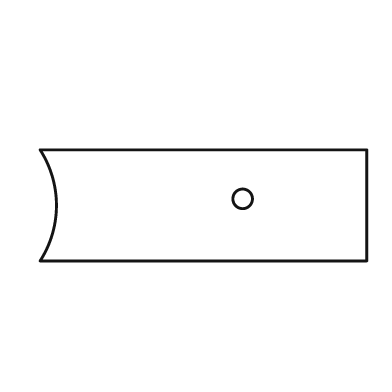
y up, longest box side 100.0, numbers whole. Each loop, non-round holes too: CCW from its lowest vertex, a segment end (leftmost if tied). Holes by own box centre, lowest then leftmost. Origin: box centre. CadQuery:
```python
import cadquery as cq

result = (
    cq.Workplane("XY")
    .moveTo(-50.0, -17.0)
    .lineTo(50.0, -17.0)
    .lineTo(50.0, 17.0)
    .lineTo(-50.0, 17.0)
    .threePointArc((-45.0, 0.0), (-50.0, -17.0))
    .close()
    .moveTo(12.0, 2.0)
    .circle(3.0)
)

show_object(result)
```